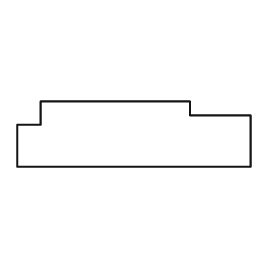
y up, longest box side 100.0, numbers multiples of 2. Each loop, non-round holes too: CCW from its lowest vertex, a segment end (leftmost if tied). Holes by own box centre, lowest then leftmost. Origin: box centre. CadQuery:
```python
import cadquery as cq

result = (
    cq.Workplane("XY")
    .moveTo(-50.0, -14.0)
    .lineTo(50.0, -14.0)
    .lineTo(50.0, 8.0)
    .lineTo(24.0, 8.0)
    .lineTo(24.0, 14.0)
    .lineTo(-40.0, 14.0)
    .lineTo(-40.0, 4.0)
    .lineTo(-50.0, 4.0)
    .close()
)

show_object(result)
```